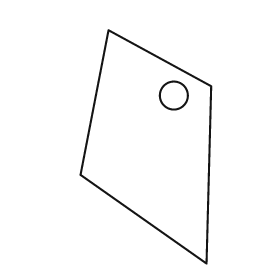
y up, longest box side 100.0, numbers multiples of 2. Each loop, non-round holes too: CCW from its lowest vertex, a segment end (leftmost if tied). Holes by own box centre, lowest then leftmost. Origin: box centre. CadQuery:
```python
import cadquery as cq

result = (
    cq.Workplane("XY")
    .moveTo(26.0, -50.0)
    .lineTo(28.0, 26.0)
    .lineTo(-16.0, 50.0)
    .lineTo(-28.0, -12.0)
    .close()
    .moveTo(12.0, 22.0)
    .circle(6.0)
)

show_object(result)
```